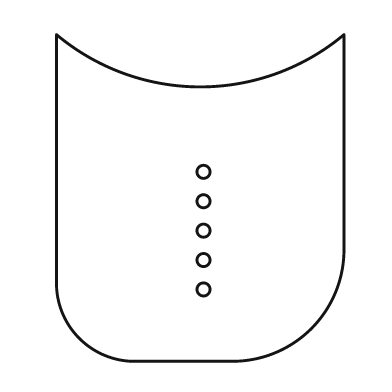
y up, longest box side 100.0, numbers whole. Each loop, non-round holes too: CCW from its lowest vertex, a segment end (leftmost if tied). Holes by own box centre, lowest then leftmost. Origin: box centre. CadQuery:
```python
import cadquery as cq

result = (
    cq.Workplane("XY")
    .moveTo(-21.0, -50.0)
    .lineTo(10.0, -50.0)
    .threePointArc((34.0, -40.0), (44.0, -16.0))
    .lineTo(44.0, 50.0)
    .threePointArc((0.0, 34.0), (-44.0, 50.0))
    .lineTo(-44.0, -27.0)
    .threePointArc((-37.0, -43.0), (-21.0, -50.0))
    .close()
    .moveTo(1.0, -28.0)
    .circle(2.0)
    .moveTo(1.0, -19.0)
    .circle(2.0)
    .moveTo(1.0, -10.0)
    .circle(2.0)
    .moveTo(1.0, -1.0)
    .circle(2.0)
    .moveTo(1.0, 8.0)
    .circle(2.0)
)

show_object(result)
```